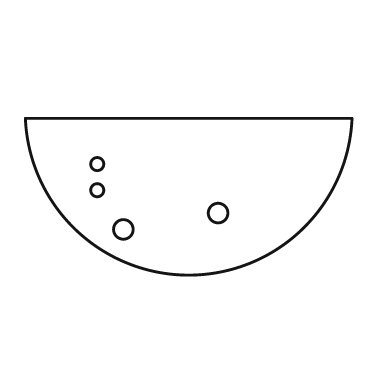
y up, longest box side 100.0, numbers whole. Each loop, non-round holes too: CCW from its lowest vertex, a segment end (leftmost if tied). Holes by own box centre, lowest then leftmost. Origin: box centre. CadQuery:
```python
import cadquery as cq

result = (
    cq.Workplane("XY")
    .moveTo(-50.0, 24.0)
    .threePointArc((0.0, -24.0), (50.0, 24.0))
    .close()
    .moveTo(-20.0, -10.0)
    .circle(3.0)
    .moveTo(9.0, -5.0)
    .circle(3.0)
    .moveTo(-28.0, 2.0)
    .circle(2.0)
    .moveTo(-28.0, 10.0)
    .circle(2.0)
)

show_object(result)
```